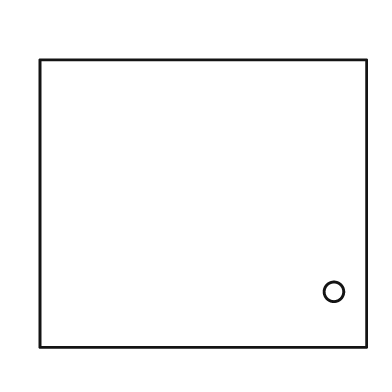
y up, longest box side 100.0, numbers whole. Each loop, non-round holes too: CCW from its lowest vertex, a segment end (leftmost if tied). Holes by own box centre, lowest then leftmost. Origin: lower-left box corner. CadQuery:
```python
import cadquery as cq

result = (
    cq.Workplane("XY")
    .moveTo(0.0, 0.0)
    .lineTo(100.0, 0.0)
    .lineTo(100.0, 88.0)
    .lineTo(0.0, 88.0)
    .close()
    .moveTo(90.0, 17.0)
    .circle(3.0)
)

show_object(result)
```